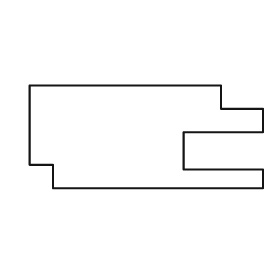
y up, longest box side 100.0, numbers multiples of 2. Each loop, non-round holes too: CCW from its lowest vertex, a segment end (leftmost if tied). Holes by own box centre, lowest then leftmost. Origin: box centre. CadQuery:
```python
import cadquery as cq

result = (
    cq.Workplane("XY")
    .moveTo(-40.0, -22.0)
    .lineTo(50.0, -22.0)
    .lineTo(50.0, -14.0)
    .lineTo(16.0, -14.0)
    .lineTo(16.0, 2.0)
    .lineTo(50.0, 2.0)
    .lineTo(50.0, 12.0)
    .lineTo(32.0, 12.0)
    .lineTo(32.0, 22.0)
    .lineTo(-50.0, 22.0)
    .lineTo(-50.0, -12.0)
    .lineTo(-40.0, -12.0)
    .close()
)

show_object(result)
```